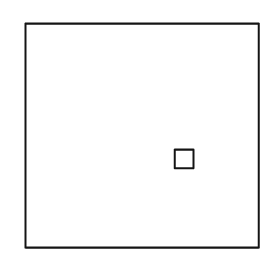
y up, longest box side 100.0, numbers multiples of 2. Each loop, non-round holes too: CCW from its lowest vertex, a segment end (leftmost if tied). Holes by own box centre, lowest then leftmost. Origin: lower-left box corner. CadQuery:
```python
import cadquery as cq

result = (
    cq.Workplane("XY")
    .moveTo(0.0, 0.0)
    .lineTo(100.0, 0.0)
    .lineTo(100.0, 96.0)
    .lineTo(0.0, 96.0)
    .close()
    .moveTo(64.0, 34.0)
    .lineTo(72.0, 34.0)
    .lineTo(72.0, 42.0)
    .lineTo(64.0, 42.0)
    .close()
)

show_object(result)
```